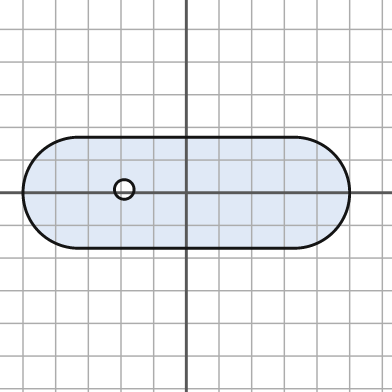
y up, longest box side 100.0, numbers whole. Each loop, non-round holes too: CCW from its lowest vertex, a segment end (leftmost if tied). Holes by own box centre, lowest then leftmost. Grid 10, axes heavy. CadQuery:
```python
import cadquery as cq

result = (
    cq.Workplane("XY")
    .moveTo(-33.0, -17.0)
    .lineTo(33.0, -17.0)
    .threePointArc((50.0, 0.0), (33.0, 17.0))
    .lineTo(-33.0, 17.0)
    .threePointArc((-50.0, 0.0), (-33.0, -17.0))
    .close()
    .moveTo(-19.0, 1.0)
    .circle(3.0)
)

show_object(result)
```